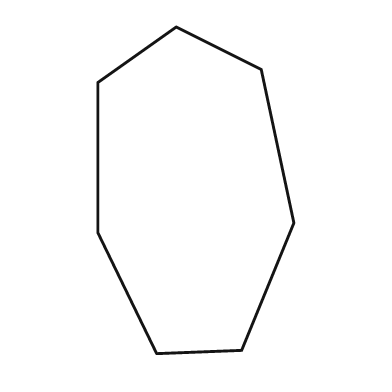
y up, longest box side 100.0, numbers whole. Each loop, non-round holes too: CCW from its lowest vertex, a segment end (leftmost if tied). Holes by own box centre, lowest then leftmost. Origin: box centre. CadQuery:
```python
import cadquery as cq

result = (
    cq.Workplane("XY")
    .moveTo(-12.0, -50.0)
    .lineTo(14.0, -49.0)
    .lineTo(30.0, -10.0)
    .lineTo(20.0, 37.0)
    .lineTo(-6.0, 50.0)
    .lineTo(-30.0, 33.0)
    .lineTo(-30.0, -13.0)
    .close()
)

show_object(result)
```